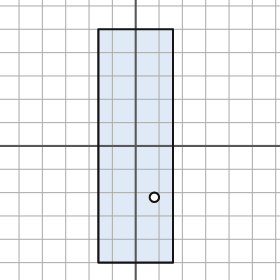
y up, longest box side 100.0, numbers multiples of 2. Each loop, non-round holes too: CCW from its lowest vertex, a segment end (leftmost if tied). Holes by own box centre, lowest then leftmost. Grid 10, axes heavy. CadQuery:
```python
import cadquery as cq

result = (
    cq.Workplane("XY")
    .moveTo(-16.0, -50.0)
    .lineTo(16.0, -50.0)
    .lineTo(16.0, 50.0)
    .lineTo(-16.0, 50.0)
    .close()
    .moveTo(8.0, -22.0)
    .circle(2.0)
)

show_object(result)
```